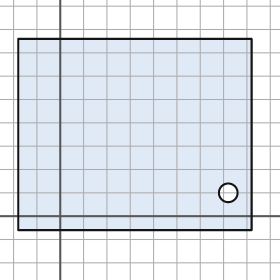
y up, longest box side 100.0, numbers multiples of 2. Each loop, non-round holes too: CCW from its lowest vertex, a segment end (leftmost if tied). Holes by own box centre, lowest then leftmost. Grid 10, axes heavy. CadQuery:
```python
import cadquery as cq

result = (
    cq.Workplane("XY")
    .moveTo(-18.0, -6.0)
    .lineTo(82.0, -6.0)
    .lineTo(82.0, 76.0)
    .lineTo(-18.0, 76.0)
    .close()
    .moveTo(72.0, 10.0)
    .circle(4.0)
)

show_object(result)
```